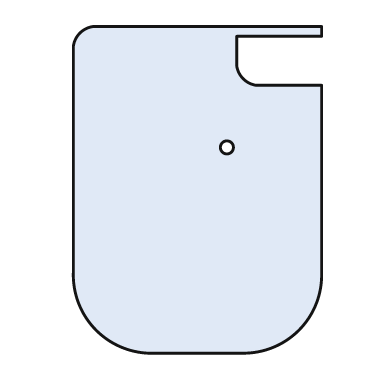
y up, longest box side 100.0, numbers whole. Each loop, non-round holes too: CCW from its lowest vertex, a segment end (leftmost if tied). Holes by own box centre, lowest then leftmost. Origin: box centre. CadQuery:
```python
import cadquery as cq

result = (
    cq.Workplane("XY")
    .moveTo(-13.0, -50.0)
    .lineTo(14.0, -50.0)
    .threePointArc((31.0, -43.0), (38.0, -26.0))
    .lineTo(38.0, 32.0)
    .lineTo(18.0, 32.0)
    .threePointArc((14.0, 34.0), (12.0, 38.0))
    .lineTo(12.0, 47.0)
    .lineTo(38.0, 47.0)
    .lineTo(38.0, 50.0)
    .lineTo(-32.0, 50.0)
    .threePointArc((-36.0, 48.0), (-38.0, 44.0))
    .lineTo(-38.0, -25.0)
    .threePointArc((-31.0, -43.0), (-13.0, -50.0))
    .close()
    .moveTo(9.0, 13.0)
    .circle(2.0)
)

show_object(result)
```